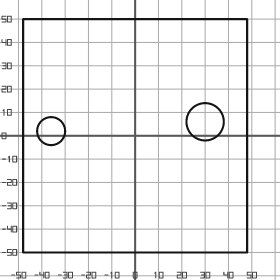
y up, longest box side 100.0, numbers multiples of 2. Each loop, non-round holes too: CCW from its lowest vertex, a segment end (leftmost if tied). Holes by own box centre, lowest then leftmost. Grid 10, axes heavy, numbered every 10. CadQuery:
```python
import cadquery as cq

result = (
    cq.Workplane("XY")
    .moveTo(-48.0, -50.0)
    .lineTo(48.0, -50.0)
    .lineTo(48.0, 50.0)
    .lineTo(-48.0, 50.0)
    .close()
    .moveTo(-36.0, 2.0)
    .circle(6.0)
    .moveTo(30.0, 6.0)
    .circle(8.0)
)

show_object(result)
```